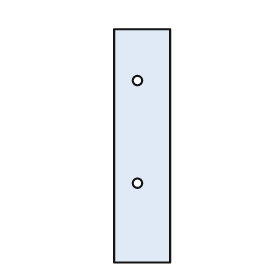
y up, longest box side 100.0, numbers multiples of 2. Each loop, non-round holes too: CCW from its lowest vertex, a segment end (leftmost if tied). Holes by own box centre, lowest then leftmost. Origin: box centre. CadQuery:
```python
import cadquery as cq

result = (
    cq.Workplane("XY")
    .moveTo(-12.0, -50.0)
    .lineTo(12.0, -50.0)
    .lineTo(12.0, 50.0)
    .lineTo(-12.0, 50.0)
    .close()
    .moveTo(-2.0, -16.0)
    .circle(2.0)
    .moveTo(-2.0, 28.0)
    .circle(2.0)
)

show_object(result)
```